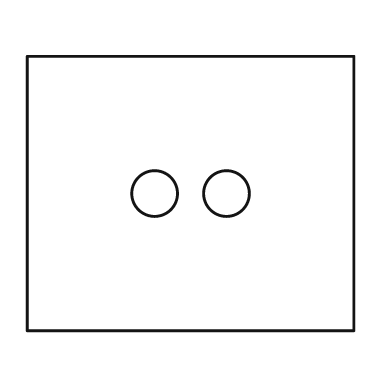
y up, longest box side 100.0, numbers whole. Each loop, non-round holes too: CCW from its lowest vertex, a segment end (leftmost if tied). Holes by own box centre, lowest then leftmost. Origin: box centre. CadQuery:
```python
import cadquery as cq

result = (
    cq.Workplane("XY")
    .moveTo(-50.0, -42.0)
    .lineTo(50.0, -42.0)
    .lineTo(50.0, 42.0)
    .lineTo(-50.0, 42.0)
    .close()
    .moveTo(-11.0, 0.0)
    .circle(7.0)
    .moveTo(11.0, 0.0)
    .circle(7.0)
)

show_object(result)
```